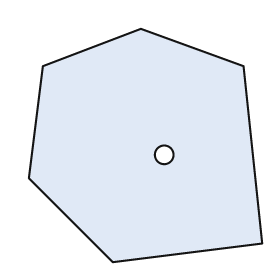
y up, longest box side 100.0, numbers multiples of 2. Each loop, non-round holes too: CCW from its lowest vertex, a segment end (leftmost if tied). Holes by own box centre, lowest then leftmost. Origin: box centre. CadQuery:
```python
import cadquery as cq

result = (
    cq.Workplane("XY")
    .moveTo(-14.0, -50.0)
    .lineTo(50.0, -42.0)
    .lineTo(42.0, 34.0)
    .lineTo(-2.0, 50.0)
    .lineTo(-44.0, 34.0)
    .lineTo(-50.0, -14.0)
    .close()
    .moveTo(8.0, -4.0)
    .circle(4.0)
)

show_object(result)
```